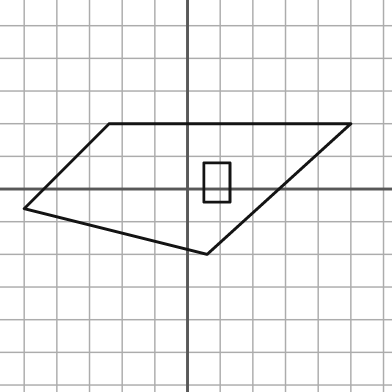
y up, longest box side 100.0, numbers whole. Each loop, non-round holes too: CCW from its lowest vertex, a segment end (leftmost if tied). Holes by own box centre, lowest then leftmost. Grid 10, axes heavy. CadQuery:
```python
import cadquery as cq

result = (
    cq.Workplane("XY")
    .moveTo(6.0, -20.0)
    .lineTo(50.0, 20.0)
    .lineTo(-24.0, 20.0)
    .lineTo(-50.0, -6.0)
    .close()
    .moveTo(5.0, -4.0)
    .lineTo(13.0, -4.0)
    .lineTo(13.0, 8.0)
    .lineTo(5.0, 8.0)
    .close()
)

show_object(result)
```